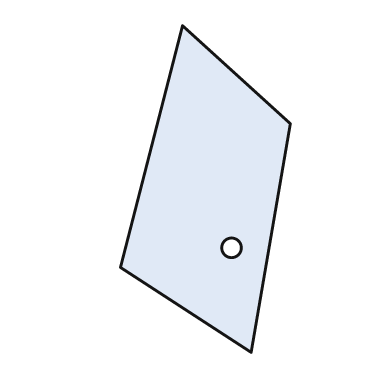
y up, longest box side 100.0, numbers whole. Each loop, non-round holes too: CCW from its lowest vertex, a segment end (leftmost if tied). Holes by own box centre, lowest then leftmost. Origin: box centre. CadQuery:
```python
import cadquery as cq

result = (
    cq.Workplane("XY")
    .moveTo(14.0, -50.0)
    .lineTo(26.0, 20.0)
    .lineTo(-7.0, 50.0)
    .lineTo(-26.0, -24.0)
    .close()
    .moveTo(8.0, -18.0)
    .circle(3.0)
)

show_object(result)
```